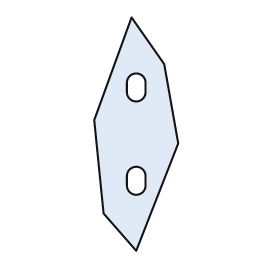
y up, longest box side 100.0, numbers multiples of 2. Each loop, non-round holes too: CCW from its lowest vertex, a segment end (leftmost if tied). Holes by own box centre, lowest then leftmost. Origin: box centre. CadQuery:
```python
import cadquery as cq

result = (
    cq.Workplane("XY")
    .moveTo(0.0, -50.0)
    .lineTo(18.0, -4.0)
    .lineTo(12.0, 30.0)
    .lineTo(-2.0, 50.0)
    .lineTo(-18.0, 6.0)
    .lineTo(-14.0, -34.0)
    .close()
    .moveTo(-4.0, -22.0)
    .threePointArc((0.0, -26.0), (4.0, -22.0))
    .lineTo(4.0, -18.0)
    .threePointArc((0.0, -14.0), (-4.0, -18.0))
    .close()
    .moveTo(-4.0, 18.0)
    .threePointArc((0.0, 14.0), (4.0, 18.0))
    .lineTo(4.0, 22.0)
    .threePointArc((0.0, 26.0), (-4.0, 22.0))
    .close()
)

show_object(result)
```